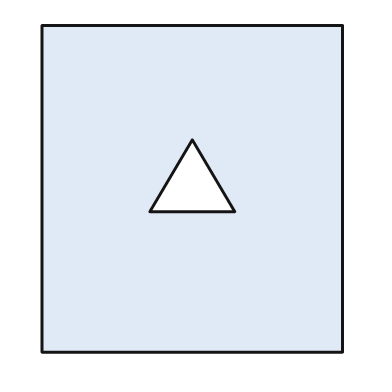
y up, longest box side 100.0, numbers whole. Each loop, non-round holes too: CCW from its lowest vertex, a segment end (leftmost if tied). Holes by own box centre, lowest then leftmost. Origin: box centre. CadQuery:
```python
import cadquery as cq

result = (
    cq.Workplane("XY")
    .moveTo(-46.0, -50.0)
    .lineTo(46.0, -50.0)
    .lineTo(46.0, 50.0)
    .lineTo(-46.0, 50.0)
    .close()
    .moveTo(-13.0, -7.0)
    .lineTo(13.0, -7.0)
    .lineTo(0.0, 15.0)
    .close()
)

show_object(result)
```